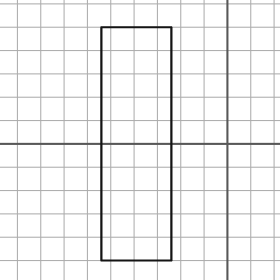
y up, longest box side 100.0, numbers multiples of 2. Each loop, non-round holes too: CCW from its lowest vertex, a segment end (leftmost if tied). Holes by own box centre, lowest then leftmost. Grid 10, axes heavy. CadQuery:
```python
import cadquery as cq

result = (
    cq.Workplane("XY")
    .moveTo(-54.0, -50.0)
    .lineTo(-24.0, -50.0)
    .lineTo(-24.0, 50.0)
    .lineTo(-54.0, 50.0)
    .close()
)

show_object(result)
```